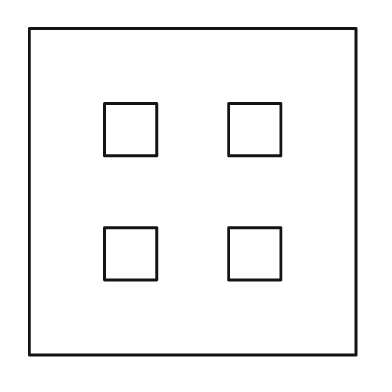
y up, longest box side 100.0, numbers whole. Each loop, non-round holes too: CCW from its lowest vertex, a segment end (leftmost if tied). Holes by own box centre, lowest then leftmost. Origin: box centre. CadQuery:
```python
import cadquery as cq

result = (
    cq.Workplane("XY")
    .moveTo(-50.0, -50.0)
    .lineTo(50.0, -50.0)
    .lineTo(50.0, 50.0)
    .lineTo(-50.0, 50.0)
    .close()
    .moveTo(-27.0, -27.0)
    .lineTo(-11.0, -27.0)
    .lineTo(-11.0, -11.0)
    .lineTo(-27.0, -11.0)
    .close()
    .moveTo(11.0, -27.0)
    .lineTo(27.0, -27.0)
    .lineTo(27.0, -11.0)
    .lineTo(11.0, -11.0)
    .close()
    .moveTo(-27.0, 11.0)
    .lineTo(-11.0, 11.0)
    .lineTo(-11.0, 27.0)
    .lineTo(-27.0, 27.0)
    .close()
    .moveTo(11.0, 11.0)
    .lineTo(27.0, 11.0)
    .lineTo(27.0, 27.0)
    .lineTo(11.0, 27.0)
    .close()
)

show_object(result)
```